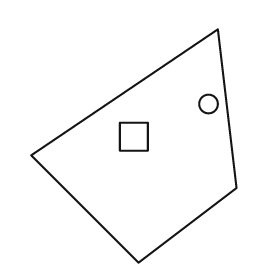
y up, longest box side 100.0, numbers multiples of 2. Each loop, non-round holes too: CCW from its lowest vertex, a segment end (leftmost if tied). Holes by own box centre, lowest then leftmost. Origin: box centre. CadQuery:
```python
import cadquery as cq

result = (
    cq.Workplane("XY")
    .moveTo(2.0, -50.0)
    .lineTo(44.0, -18.0)
    .lineTo(36.0, 50.0)
    .lineTo(-44.0, -4.0)
    .close()
    .moveTo(-6.0, -2.0)
    .lineTo(6.0, -2.0)
    .lineTo(6.0, 10.0)
    .lineTo(-6.0, 10.0)
    .close()
    .moveTo(32.0, 18.0)
    .circle(4.0)
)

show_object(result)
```